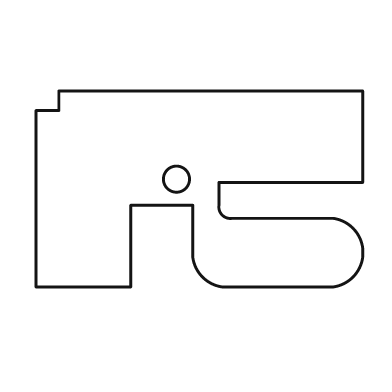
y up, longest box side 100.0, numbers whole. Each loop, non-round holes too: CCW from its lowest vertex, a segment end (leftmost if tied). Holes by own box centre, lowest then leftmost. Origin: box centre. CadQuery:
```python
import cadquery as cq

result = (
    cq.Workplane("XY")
    .moveTo(-50.0, -30.0)
    .lineTo(-21.0, -30.0)
    .lineTo(-21.0, -5.0)
    .lineTo(-2.0, -5.0)
    .lineTo(-2.0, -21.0)
    .threePointArc((1.0, -27.0), (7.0, -30.0))
    .lineTo(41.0, -30.0)
    .threePointArc((47.0, -27.0), (50.0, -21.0))
    .lineTo(50.0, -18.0)
    .threePointArc((47.0, -12.0), (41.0, -9.0))
    .lineTo(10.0, -9.0)
    .threePointArc((7.0, -8.0), (6.0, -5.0))
    .lineTo(6.0, 2.0)
    .lineTo(50.0, 2.0)
    .lineTo(50.0, 30.0)
    .lineTo(-43.0, 30.0)
    .lineTo(-43.0, 24.0)
    .lineTo(-50.0, 24.0)
    .close()
    .moveTo(-7.0, 3.0)
    .circle(4.0)
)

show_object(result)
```